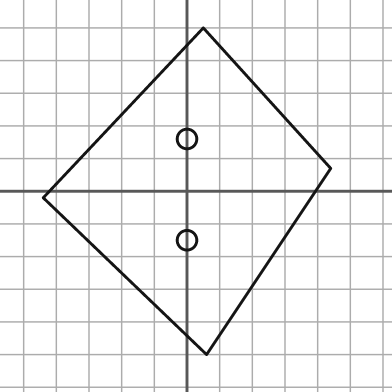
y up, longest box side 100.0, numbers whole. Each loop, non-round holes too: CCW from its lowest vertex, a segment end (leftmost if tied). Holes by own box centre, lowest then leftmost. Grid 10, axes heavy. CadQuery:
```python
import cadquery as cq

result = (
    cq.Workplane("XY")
    .moveTo(6.0, -50.0)
    .lineTo(44.0, 7.0)
    .lineTo(5.0, 50.0)
    .lineTo(-44.0, -2.0)
    .close()
    .moveTo(0.0, -15.0)
    .circle(3.0)
    .moveTo(0.0, 16.0)
    .circle(3.0)
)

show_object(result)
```